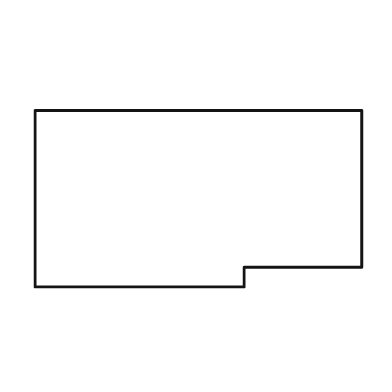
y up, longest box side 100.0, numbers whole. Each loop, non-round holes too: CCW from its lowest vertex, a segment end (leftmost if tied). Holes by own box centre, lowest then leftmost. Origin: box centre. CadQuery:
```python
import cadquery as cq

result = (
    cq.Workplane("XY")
    .moveTo(-50.0, -27.0)
    .lineTo(14.0, -27.0)
    .lineTo(14.0, -21.0)
    .lineTo(50.0, -21.0)
    .lineTo(50.0, 27.0)
    .lineTo(-50.0, 27.0)
    .close()
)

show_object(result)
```